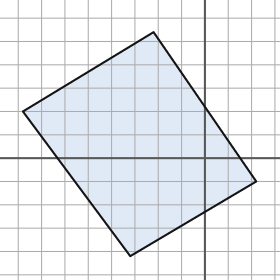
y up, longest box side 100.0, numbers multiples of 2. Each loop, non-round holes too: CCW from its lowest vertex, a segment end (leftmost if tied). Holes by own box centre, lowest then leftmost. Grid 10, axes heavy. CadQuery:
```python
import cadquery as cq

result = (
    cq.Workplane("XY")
    .moveTo(-32.0, -42.0)
    .lineTo(22.0, -10.0)
    .lineTo(-22.0, 54.0)
    .lineTo(-78.0, 20.0)
    .close()
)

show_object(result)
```